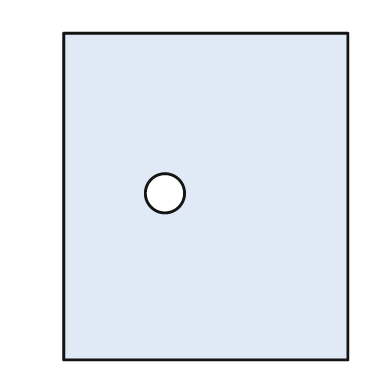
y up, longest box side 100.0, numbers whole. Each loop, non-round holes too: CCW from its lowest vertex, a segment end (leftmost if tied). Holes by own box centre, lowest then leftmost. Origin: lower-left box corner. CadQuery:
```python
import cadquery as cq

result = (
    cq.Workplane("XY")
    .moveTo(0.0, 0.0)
    .lineTo(87.0, 0.0)
    .lineTo(87.0, 100.0)
    .lineTo(0.0, 100.0)
    .close()
    .moveTo(31.0, 51.0)
    .circle(6.0)
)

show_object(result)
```